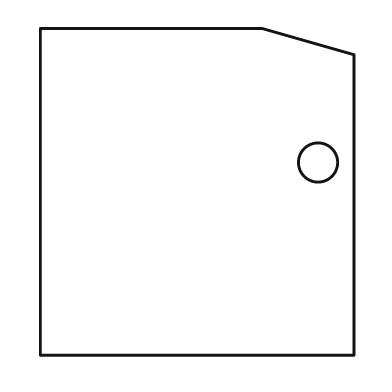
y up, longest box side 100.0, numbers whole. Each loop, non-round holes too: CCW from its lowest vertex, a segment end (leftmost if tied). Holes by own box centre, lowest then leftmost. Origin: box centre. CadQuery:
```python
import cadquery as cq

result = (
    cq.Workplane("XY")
    .moveTo(-48.0, -50.0)
    .lineTo(48.0, -50.0)
    .lineTo(48.0, 42.0)
    .lineTo(20.0, 50.0)
    .lineTo(-48.0, 50.0)
    .close()
    .moveTo(37.0, 9.0)
    .circle(6.0)
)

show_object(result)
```